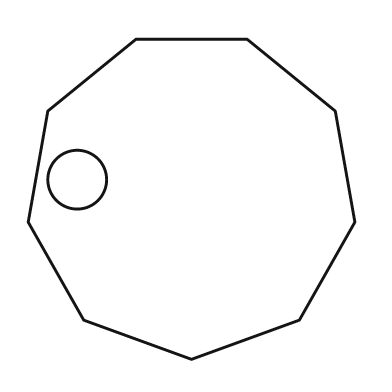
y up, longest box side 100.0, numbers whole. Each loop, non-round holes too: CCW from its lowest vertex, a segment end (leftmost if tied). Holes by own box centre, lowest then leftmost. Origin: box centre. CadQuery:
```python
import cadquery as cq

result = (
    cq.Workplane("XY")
    .moveTo(0.0, -49.0)
    .lineTo(33.0, -37.0)
    .lineTo(50.0, -7.0)
    .lineTo(44.0, 27.0)
    .lineTo(17.0, 49.0)
    .lineTo(-17.0, 49.0)
    .lineTo(-44.0, 27.0)
    .lineTo(-50.0, -7.0)
    .lineTo(-33.0, -37.0)
    .close()
    .moveTo(-35.0, 6.0)
    .circle(9.0)
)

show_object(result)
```